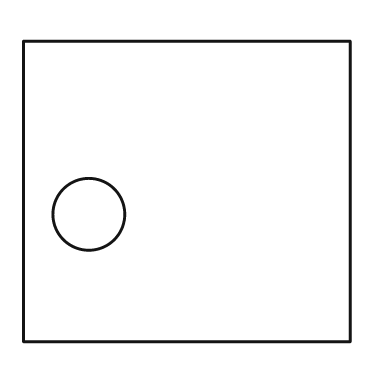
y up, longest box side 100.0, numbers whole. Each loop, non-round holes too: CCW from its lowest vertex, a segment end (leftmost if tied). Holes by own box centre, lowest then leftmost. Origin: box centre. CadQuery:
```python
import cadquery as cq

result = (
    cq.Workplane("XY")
    .moveTo(-50.0, -46.0)
    .lineTo(50.0, -46.0)
    .lineTo(50.0, 46.0)
    .lineTo(-50.0, 46.0)
    .close()
    .moveTo(-30.0, -7.0)
    .circle(11.0)
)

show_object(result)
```